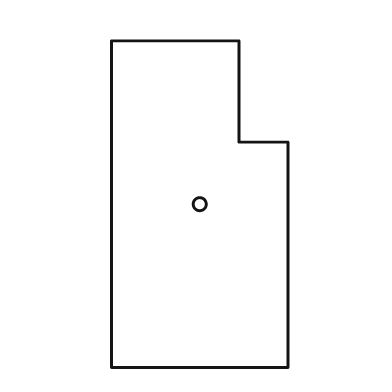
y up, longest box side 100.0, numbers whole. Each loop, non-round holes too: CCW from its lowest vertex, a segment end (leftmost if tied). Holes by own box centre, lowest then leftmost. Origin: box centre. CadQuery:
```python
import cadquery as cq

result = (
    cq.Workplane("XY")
    .moveTo(-27.0, -50.0)
    .lineTo(27.0, -50.0)
    .lineTo(27.0, 19.0)
    .lineTo(12.0, 19.0)
    .lineTo(12.0, 50.0)
    .lineTo(-27.0, 50.0)
    .close()
    .moveTo(0.0, 0.0)
    .circle(2.0)
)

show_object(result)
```